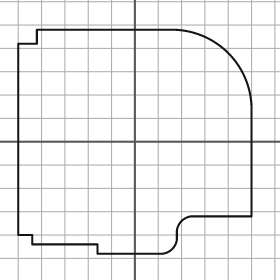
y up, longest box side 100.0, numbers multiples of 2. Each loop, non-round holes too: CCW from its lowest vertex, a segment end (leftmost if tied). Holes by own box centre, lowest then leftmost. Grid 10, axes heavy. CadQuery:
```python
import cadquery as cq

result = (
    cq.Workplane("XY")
    .moveTo(-16.0, -48.0)
    .lineTo(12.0, -48.0)
    .threePointArc((16.0, -46.0), (18.0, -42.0))
    .lineTo(18.0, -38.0)
    .threePointArc((20.0, -34.0), (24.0, -32.0))
    .lineTo(50.0, -32.0)
    .lineTo(50.0, 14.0)
    .threePointArc((40.0, 38.0), (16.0, 48.0))
    .lineTo(-42.0, 48.0)
    .lineTo(-42.0, 42.0)
    .lineTo(-50.0, 42.0)
    .lineTo(-50.0, -40.0)
    .lineTo(-44.0, -40.0)
    .lineTo(-44.0, -44.0)
    .lineTo(-16.0, -44.0)
    .close()
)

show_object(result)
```